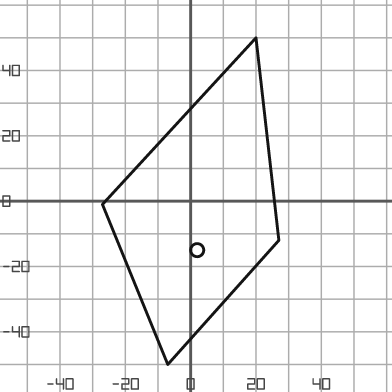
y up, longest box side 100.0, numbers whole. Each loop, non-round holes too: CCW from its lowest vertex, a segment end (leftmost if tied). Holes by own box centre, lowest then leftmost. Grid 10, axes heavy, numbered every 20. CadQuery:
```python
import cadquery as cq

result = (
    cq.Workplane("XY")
    .moveTo(-7.0, -50.0)
    .lineTo(27.0, -12.0)
    .lineTo(20.0, 50.0)
    .lineTo(-27.0, -1.0)
    .close()
    .moveTo(2.0, -15.0)
    .circle(2.0)
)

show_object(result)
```